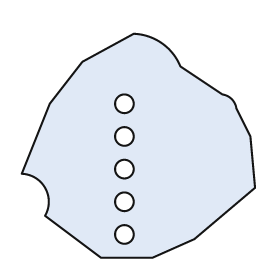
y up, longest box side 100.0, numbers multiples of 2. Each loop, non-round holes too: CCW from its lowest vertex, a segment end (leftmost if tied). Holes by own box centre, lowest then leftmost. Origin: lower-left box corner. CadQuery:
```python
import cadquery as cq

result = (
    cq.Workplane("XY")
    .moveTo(34.0, 0.0)
    .lineTo(56.0, 0.0)
    .lineTo(74.0, 8.0)
    .lineTo(100.0, 30.0)
    .lineTo(98.0, 52.0)
    .lineTo(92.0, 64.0)
    .threePointArc((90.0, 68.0), (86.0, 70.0))
    .lineTo(68.0, 82.0)
    .threePointArc((60.0, 92.0), (48.0, 96.0))
    .lineTo(26.0, 84.0)
    .lineTo(12.0, 66.0)
    .lineTo(0.0, 36.0)
    .threePointArc((10.0, 30.0), (10.0, 18.0))
    .close()
    .moveTo(44.0, 10.0)
    .circle(4.0)
    .moveTo(44.0, 24.0)
    .circle(4.0)
    .moveTo(44.0, 38.0)
    .circle(4.0)
    .moveTo(44.0, 52.0)
    .circle(4.0)
    .moveTo(44.0, 66.0)
    .circle(4.0)
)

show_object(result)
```